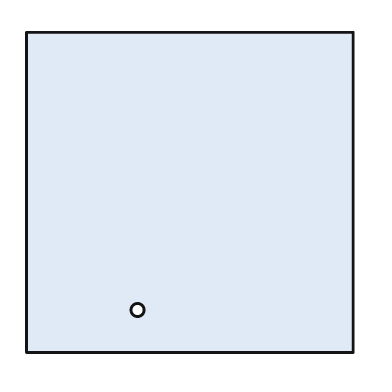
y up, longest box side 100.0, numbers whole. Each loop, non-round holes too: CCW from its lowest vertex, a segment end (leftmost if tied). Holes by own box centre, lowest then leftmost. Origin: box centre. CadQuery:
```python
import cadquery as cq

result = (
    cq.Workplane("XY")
    .moveTo(-50.0, -49.0)
    .lineTo(50.0, -49.0)
    .lineTo(50.0, 49.0)
    .lineTo(-50.0, 49.0)
    .close()
    .moveTo(-16.0, -36.0)
    .circle(2.0)
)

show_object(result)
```